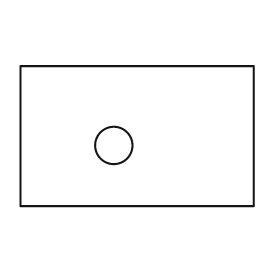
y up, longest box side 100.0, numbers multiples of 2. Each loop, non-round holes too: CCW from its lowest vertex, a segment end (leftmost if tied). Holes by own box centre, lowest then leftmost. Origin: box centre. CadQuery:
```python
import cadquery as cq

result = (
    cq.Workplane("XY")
    .moveTo(-50.0, -30.0)
    .lineTo(50.0, -30.0)
    .lineTo(50.0, 30.0)
    .lineTo(-50.0, 30.0)
    .close()
    .moveTo(-10.0, -4.0)
    .circle(8.0)
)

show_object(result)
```